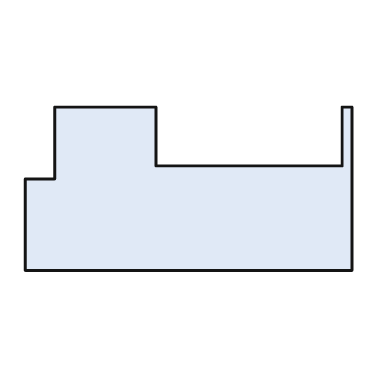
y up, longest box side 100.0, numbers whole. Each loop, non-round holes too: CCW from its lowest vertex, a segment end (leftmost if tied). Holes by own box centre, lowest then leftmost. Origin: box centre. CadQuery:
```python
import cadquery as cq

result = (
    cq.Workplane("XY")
    .moveTo(-50.0, -25.0)
    .lineTo(50.0, -25.0)
    .lineTo(50.0, 25.0)
    .lineTo(47.0, 25.0)
    .lineTo(47.0, 7.0)
    .lineTo(-10.0, 7.0)
    .lineTo(-10.0, 25.0)
    .lineTo(-41.0, 25.0)
    .lineTo(-41.0, 3.0)
    .lineTo(-50.0, 3.0)
    .close()
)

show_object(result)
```